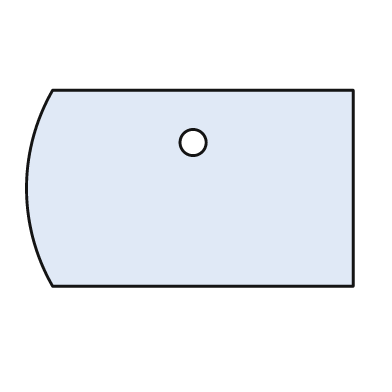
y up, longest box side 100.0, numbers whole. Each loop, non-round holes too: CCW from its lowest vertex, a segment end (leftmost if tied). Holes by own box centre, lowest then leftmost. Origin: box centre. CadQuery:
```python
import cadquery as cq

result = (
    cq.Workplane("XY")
    .moveTo(-42.0, -30.0)
    .lineTo(50.0, -30.0)
    .lineTo(50.0, 30.0)
    .lineTo(-42.0, 30.0)
    .threePointArc((-50.0, 0.0), (-42.0, -30.0))
    .close()
    .moveTo(1.0, 14.0)
    .circle(4.0)
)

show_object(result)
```